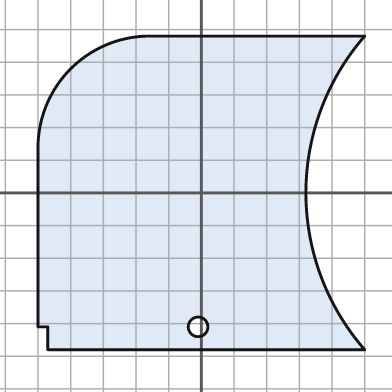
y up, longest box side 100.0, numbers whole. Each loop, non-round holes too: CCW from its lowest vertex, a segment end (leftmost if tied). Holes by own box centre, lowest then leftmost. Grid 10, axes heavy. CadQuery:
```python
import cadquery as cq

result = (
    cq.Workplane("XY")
    .moveTo(-47.0, -48.0)
    .lineTo(50.0, -48.0)
    .threePointArc((32.0, 0.0), (50.0, 48.0))
    .lineTo(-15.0, 48.0)
    .threePointArc((-40.0, 38.0), (-50.0, 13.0))
    .lineTo(-50.0, -41.0)
    .lineTo(-47.0, -41.0)
    .close()
    .moveTo(-1.0, -41.0)
    .circle(3.0)
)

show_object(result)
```